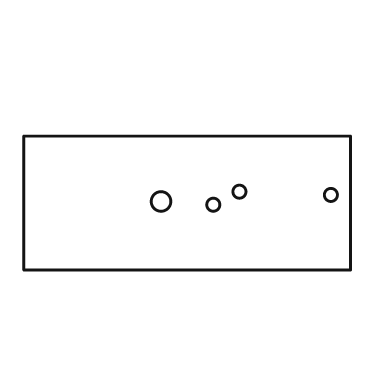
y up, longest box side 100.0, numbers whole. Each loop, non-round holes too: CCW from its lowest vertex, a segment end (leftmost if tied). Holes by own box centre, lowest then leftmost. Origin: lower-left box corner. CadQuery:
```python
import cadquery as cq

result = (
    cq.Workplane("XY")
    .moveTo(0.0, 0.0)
    .lineTo(100.0, 0.0)
    .lineTo(100.0, 41.0)
    .lineTo(0.0, 41.0)
    .close()
    .moveTo(58.0, 20.0)
    .circle(2.0)
    .moveTo(42.0, 21.0)
    .circle(3.0)
    .moveTo(94.0, 23.0)
    .circle(2.0)
    .moveTo(66.0, 24.0)
    .circle(2.0)
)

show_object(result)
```